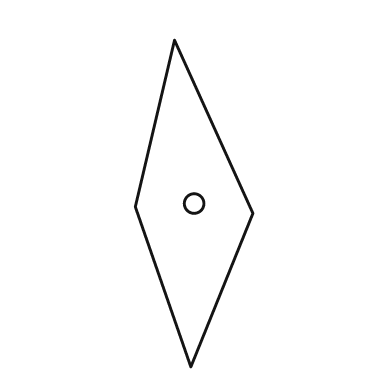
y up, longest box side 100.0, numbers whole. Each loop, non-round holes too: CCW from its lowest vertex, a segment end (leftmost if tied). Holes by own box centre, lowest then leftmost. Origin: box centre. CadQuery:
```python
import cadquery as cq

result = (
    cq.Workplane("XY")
    .moveTo(-1.0, -50.0)
    .lineTo(18.0, -3.0)
    .lineTo(-6.0, 50.0)
    .lineTo(-18.0, -1.0)
    .close()
    .moveTo(0.0, 0.0)
    .circle(3.0)
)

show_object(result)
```